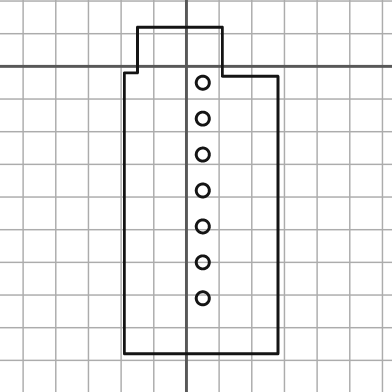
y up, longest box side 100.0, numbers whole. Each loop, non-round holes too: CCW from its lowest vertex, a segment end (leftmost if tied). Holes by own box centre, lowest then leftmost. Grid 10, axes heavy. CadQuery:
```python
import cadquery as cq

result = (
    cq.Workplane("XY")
    .moveTo(-19.0, -88.0)
    .lineTo(28.0, -88.0)
    .lineTo(28.0, -3.0)
    .lineTo(11.0, -3.0)
    .lineTo(11.0, 12.0)
    .lineTo(-15.0, 12.0)
    .lineTo(-15.0, -2.0)
    .lineTo(-19.0, -2.0)
    .close()
    .moveTo(5.0, -71.0)
    .circle(2.0)
    .moveTo(5.0, -60.0)
    .circle(2.0)
    .moveTo(5.0, -49.0)
    .circle(2.0)
    .moveTo(5.0, -38.0)
    .circle(2.0)
    .moveTo(5.0, -27.0)
    .circle(2.0)
    .moveTo(5.0, -16.0)
    .circle(2.0)
    .moveTo(5.0, -5.0)
    .circle(2.0)
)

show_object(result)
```